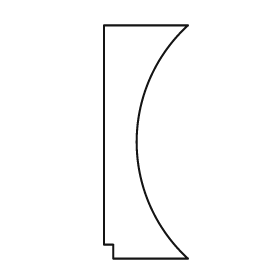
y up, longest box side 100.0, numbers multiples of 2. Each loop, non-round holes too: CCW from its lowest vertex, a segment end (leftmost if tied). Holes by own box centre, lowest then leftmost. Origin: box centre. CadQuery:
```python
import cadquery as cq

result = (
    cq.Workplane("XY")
    .moveTo(-14.0, -50.0)
    .lineTo(18.0, -50.0)
    .threePointArc((-4.0, 0.0), (18.0, 50.0))
    .lineTo(-18.0, 50.0)
    .lineTo(-18.0, -44.0)
    .lineTo(-14.0, -44.0)
    .close()
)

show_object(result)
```